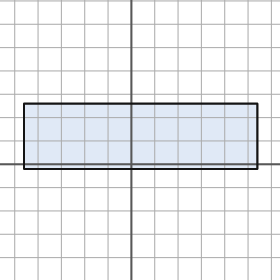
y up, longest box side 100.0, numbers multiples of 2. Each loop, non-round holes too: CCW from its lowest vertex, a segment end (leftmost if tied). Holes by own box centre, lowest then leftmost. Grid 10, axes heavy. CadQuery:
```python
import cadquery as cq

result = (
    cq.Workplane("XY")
    .moveTo(-46.0, -2.0)
    .lineTo(54.0, -2.0)
    .lineTo(54.0, 26.0)
    .lineTo(-46.0, 26.0)
    .close()
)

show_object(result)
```